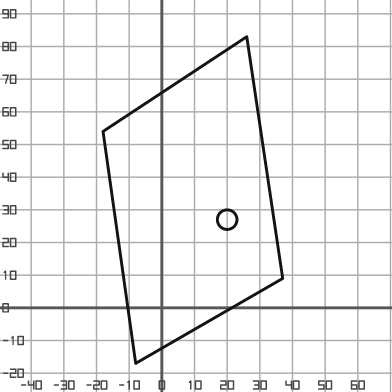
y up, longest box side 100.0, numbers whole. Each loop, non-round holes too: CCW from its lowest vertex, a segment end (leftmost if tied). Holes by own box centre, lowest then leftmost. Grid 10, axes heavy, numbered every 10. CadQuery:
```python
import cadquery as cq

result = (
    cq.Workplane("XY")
    .moveTo(-8.0, -17.0)
    .lineTo(37.0, 9.0)
    .lineTo(26.0, 83.0)
    .lineTo(-18.0, 54.0)
    .close()
    .moveTo(20.0, 27.0)
    .circle(3.0)
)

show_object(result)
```